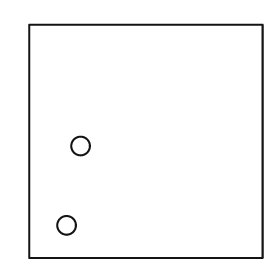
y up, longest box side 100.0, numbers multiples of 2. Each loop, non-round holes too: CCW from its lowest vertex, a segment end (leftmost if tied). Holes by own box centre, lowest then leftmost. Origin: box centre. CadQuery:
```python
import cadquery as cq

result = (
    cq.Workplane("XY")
    .moveTo(-50.0, -50.0)
    .lineTo(50.0, -50.0)
    .lineTo(50.0, 50.0)
    .lineTo(-50.0, 50.0)
    .close()
    .moveTo(-34.0, -36.0)
    .circle(4.0)
    .moveTo(-28.0, -2.0)
    .circle(4.0)
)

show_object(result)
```